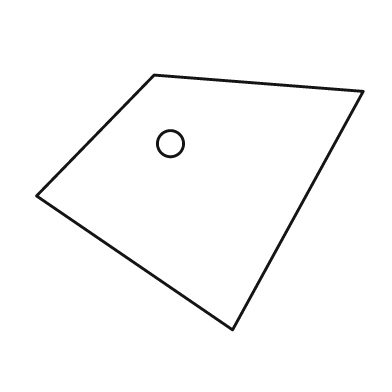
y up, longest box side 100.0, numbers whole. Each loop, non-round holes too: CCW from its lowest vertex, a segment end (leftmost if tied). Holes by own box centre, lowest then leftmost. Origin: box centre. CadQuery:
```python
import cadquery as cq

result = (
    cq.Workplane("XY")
    .moveTo(10.0, -39.0)
    .lineTo(50.0, 34.0)
    .lineTo(-14.0, 39.0)
    .lineTo(-50.0, 2.0)
    .close()
    .moveTo(-9.0, 18.0)
    .circle(4.0)
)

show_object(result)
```